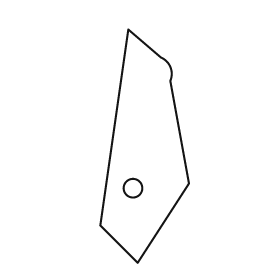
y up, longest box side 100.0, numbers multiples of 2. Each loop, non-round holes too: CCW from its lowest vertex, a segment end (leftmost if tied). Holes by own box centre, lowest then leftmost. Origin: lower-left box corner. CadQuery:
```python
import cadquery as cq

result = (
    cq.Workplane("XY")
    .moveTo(16.0, 0.0)
    .lineTo(38.0, 34.0)
    .lineTo(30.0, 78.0)
    .threePointArc((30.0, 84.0), (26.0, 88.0))
    .lineTo(12.0, 100.0)
    .lineTo(0.0, 16.0)
    .close()
    .moveTo(14.0, 32.0)
    .circle(4.0)
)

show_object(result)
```